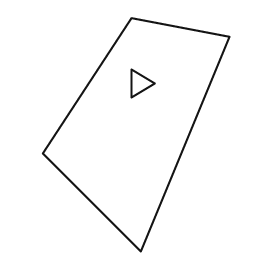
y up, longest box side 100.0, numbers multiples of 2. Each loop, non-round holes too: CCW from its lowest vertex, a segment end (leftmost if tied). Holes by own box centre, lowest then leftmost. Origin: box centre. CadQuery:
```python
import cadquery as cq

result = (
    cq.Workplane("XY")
    .moveTo(2.0, -50.0)
    .lineTo(40.0, 42.0)
    .lineTo(-2.0, 50.0)
    .lineTo(-40.0, -8.0)
    .close()
    .moveTo(-2.0, 16.0)
    .lineTo(8.0, 22.0)
    .lineTo(-2.0, 28.0)
    .close()
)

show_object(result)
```